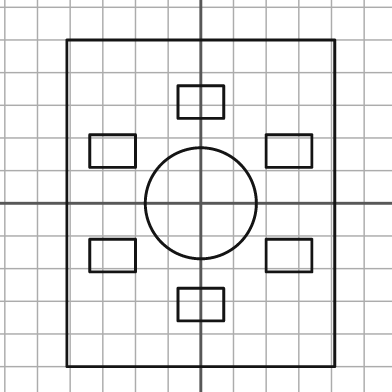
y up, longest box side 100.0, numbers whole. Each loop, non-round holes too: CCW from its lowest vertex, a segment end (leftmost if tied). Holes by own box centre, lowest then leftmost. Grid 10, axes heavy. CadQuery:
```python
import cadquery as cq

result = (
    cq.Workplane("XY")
    .moveTo(-41.0, -50.0)
    .lineTo(41.0, -50.0)
    .lineTo(41.0, 50.0)
    .lineTo(-41.0, 50.0)
    .close()
    .moveTo(-7.0, -36.0)
    .lineTo(7.0, -36.0)
    .lineTo(7.0, -26.0)
    .lineTo(-7.0, -26.0)
    .close()
    .moveTo(-34.0, -21.0)
    .lineTo(-20.0, -21.0)
    .lineTo(-20.0, -11.0)
    .lineTo(-34.0, -11.0)
    .close()
    .moveTo(20.0, -21.0)
    .lineTo(34.0, -21.0)
    .lineTo(34.0, -11.0)
    .lineTo(20.0, -11.0)
    .close()
    .moveTo(0.0, 0.0)
    .circle(17.0)
    .moveTo(-34.0, 11.0)
    .lineTo(-20.0, 11.0)
    .lineTo(-20.0, 21.0)
    .lineTo(-34.0, 21.0)
    .close()
    .moveTo(20.0, 11.0)
    .lineTo(34.0, 11.0)
    .lineTo(34.0, 21.0)
    .lineTo(20.0, 21.0)
    .close()
    .moveTo(-7.0, 26.0)
    .lineTo(7.0, 26.0)
    .lineTo(7.0, 36.0)
    .lineTo(-7.0, 36.0)
    .close()
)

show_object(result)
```